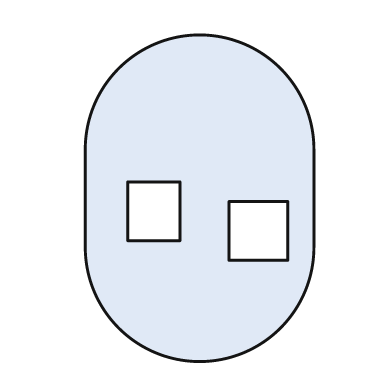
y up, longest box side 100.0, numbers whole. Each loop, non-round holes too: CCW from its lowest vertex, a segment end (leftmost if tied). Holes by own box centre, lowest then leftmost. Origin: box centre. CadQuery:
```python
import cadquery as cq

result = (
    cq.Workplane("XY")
    .moveTo(-35.0, -15.0)
    .threePointArc((0.0, -50.0), (35.0, -15.0))
    .lineTo(35.0, 15.0)
    .threePointArc((0.0, 50.0), (-35.0, 15.0))
    .close()
    .moveTo(9.0, -19.0)
    .lineTo(27.0, -19.0)
    .lineTo(27.0, -1.0)
    .lineTo(9.0, -1.0)
    .close()
    .moveTo(-22.0, -13.0)
    .lineTo(-6.0, -13.0)
    .lineTo(-6.0, 5.0)
    .lineTo(-22.0, 5.0)
    .close()
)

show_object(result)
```